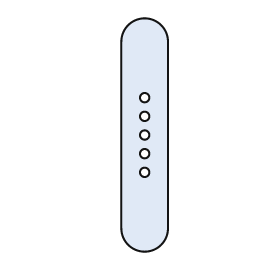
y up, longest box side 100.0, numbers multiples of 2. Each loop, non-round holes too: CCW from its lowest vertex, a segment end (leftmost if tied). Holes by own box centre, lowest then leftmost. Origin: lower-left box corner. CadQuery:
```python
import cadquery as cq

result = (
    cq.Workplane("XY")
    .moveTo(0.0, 10.0)
    .threePointArc((10.0, 0.0), (20.0, 10.0))
    .lineTo(20.0, 90.0)
    .threePointArc((10.0, 100.0), (0.0, 90.0))
    .close()
    .moveTo(10.0, 34.0)
    .circle(2.0)
    .moveTo(10.0, 42.0)
    .circle(2.0)
    .moveTo(10.0, 50.0)
    .circle(2.0)
    .moveTo(10.0, 58.0)
    .circle(2.0)
    .moveTo(10.0, 66.0)
    .circle(2.0)
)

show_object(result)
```